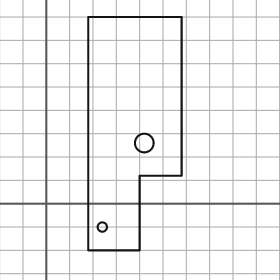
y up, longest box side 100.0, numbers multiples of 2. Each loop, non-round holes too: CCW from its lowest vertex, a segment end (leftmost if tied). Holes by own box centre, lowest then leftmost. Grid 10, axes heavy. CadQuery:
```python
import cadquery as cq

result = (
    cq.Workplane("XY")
    .moveTo(18.0, -20.0)
    .lineTo(40.0, -20.0)
    .lineTo(40.0, 12.0)
    .lineTo(58.0, 12.0)
    .lineTo(58.0, 80.0)
    .lineTo(18.0, 80.0)
    .close()
    .moveTo(24.0, -10.0)
    .circle(2.0)
    .moveTo(42.0, 26.0)
    .circle(4.0)
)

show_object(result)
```